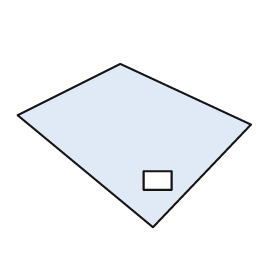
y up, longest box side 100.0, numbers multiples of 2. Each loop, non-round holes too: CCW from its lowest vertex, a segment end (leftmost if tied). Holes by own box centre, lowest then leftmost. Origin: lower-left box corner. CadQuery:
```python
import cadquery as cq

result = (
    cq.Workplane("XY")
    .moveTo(58.0, 0.0)
    .lineTo(100.0, 44.0)
    .lineTo(44.0, 70.0)
    .lineTo(0.0, 48.0)
    .close()
    .moveTo(54.0, 16.0)
    .lineTo(66.0, 16.0)
    .lineTo(66.0, 24.0)
    .lineTo(54.0, 24.0)
    .close()
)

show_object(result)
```